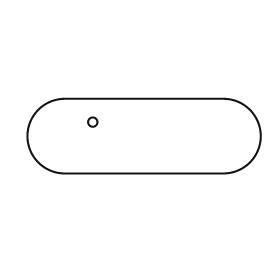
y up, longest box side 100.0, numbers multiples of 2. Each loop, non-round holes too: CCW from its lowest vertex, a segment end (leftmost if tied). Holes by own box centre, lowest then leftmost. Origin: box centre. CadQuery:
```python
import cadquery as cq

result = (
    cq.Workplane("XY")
    .moveTo(-34.0, -16.0)
    .lineTo(34.0, -16.0)
    .threePointArc((50.0, 0.0), (34.0, 16.0))
    .lineTo(-34.0, 16.0)
    .threePointArc((-50.0, 0.0), (-34.0, -16.0))
    .close()
    .moveTo(-22.0, 6.0)
    .circle(2.0)
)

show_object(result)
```